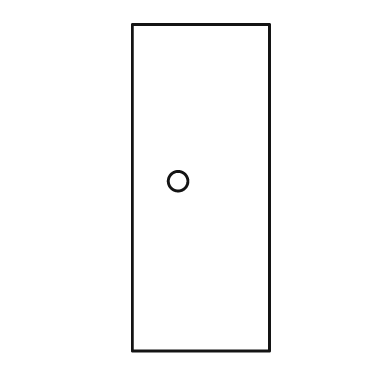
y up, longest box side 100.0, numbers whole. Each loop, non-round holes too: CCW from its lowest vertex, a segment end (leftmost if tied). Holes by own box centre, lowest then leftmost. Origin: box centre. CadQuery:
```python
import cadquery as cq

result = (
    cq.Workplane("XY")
    .moveTo(-21.0, -50.0)
    .lineTo(21.0, -50.0)
    .lineTo(21.0, 50.0)
    .lineTo(-21.0, 50.0)
    .close()
    .moveTo(-7.0, 2.0)
    .circle(3.0)
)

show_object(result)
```